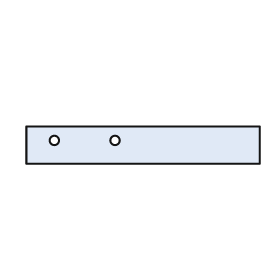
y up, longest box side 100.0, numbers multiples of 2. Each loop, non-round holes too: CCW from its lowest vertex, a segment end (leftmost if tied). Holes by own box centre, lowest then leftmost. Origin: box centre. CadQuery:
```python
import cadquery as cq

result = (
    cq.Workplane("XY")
    .moveTo(-50.0, -8.0)
    .lineTo(50.0, -8.0)
    .lineTo(50.0, 8.0)
    .lineTo(-50.0, 8.0)
    .close()
    .moveTo(-38.0, 2.0)
    .circle(2.0)
    .moveTo(-12.0, 2.0)
    .circle(2.0)
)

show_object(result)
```